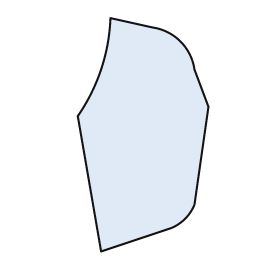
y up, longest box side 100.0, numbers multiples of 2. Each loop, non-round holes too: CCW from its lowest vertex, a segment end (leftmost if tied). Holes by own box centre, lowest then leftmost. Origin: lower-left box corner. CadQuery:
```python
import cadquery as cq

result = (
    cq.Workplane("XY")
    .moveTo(10.0, 0.0)
    .lineTo(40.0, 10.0)
    .threePointArc((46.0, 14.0), (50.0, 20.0))
    .lineTo(56.0, 62.0)
    .lineTo(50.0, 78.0)
    .threePointArc((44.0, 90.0), (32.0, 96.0))
    .lineTo(14.0, 100.0)
    .threePointArc((10.0, 78.0), (0.0, 58.0))
    .close()
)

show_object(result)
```